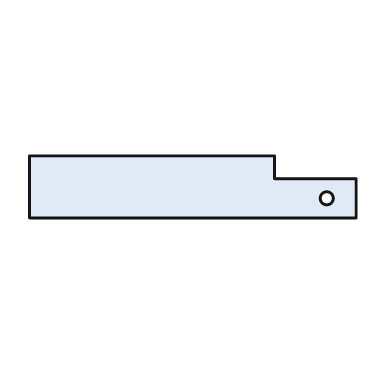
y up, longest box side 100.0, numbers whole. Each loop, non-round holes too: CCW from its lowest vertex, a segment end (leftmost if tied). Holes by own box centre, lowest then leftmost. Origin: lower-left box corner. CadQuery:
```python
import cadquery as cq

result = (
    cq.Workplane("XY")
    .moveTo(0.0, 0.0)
    .lineTo(100.0, 0.0)
    .lineTo(100.0, 12.0)
    .lineTo(75.0, 12.0)
    .lineTo(75.0, 19.0)
    .lineTo(0.0, 19.0)
    .close()
    .moveTo(91.0, 6.0)
    .circle(2.0)
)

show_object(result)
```